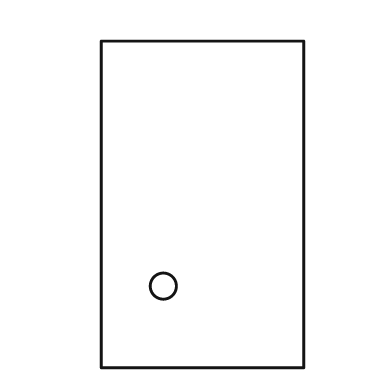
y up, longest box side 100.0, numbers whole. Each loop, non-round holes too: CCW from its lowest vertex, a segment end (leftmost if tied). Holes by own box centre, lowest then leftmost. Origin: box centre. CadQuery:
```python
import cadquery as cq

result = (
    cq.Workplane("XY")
    .moveTo(-31.0, -50.0)
    .lineTo(31.0, -50.0)
    .lineTo(31.0, 50.0)
    .lineTo(-31.0, 50.0)
    .close()
    .moveTo(-12.0, -25.0)
    .circle(4.0)
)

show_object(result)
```